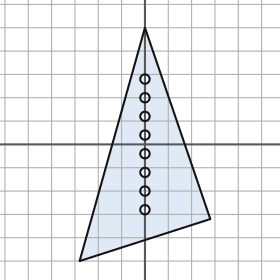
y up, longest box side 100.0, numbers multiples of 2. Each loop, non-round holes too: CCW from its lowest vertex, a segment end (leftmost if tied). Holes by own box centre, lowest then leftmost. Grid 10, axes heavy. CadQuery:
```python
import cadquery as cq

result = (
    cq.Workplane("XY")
    .moveTo(-28.0, -50.0)
    .lineTo(28.0, -32.0)
    .lineTo(0.0, 50.0)
    .close()
    .moveTo(0.0, -28.0)
    .circle(2.0)
    .moveTo(0.0, -20.0)
    .circle(2.0)
    .moveTo(0.0, -12.0)
    .circle(2.0)
    .moveTo(0.0, -4.0)
    .circle(2.0)
    .moveTo(0.0, 4.0)
    .circle(2.0)
    .moveTo(0.0, 12.0)
    .circle(2.0)
    .moveTo(0.0, 20.0)
    .circle(2.0)
    .moveTo(0.0, 28.0)
    .circle(2.0)
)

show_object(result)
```